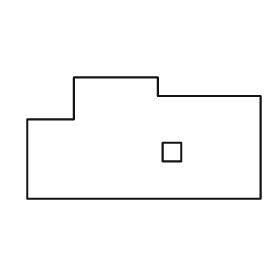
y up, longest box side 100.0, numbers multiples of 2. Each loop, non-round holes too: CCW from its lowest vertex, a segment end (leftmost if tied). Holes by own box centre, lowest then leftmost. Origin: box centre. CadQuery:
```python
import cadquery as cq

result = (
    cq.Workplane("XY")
    .moveTo(-50.0, -26.0)
    .lineTo(50.0, -26.0)
    .lineTo(50.0, 18.0)
    .lineTo(6.0, 18.0)
    .lineTo(6.0, 26.0)
    .lineTo(-30.0, 26.0)
    .lineTo(-30.0, 8.0)
    .lineTo(-50.0, 8.0)
    .close()
    .moveTo(8.0, -10.0)
    .lineTo(16.0, -10.0)
    .lineTo(16.0, -2.0)
    .lineTo(8.0, -2.0)
    .close()
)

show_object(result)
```